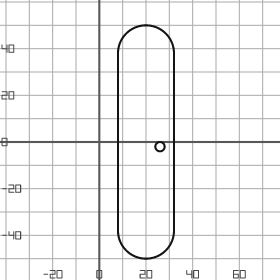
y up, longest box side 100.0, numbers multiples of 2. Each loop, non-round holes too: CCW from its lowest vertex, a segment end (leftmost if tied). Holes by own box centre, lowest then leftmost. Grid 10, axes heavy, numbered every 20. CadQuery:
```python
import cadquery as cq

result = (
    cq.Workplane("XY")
    .moveTo(8.0, -38.0)
    .threePointArc((20.0, -50.0), (32.0, -38.0))
    .lineTo(32.0, 38.0)
    .threePointArc((20.0, 50.0), (8.0, 38.0))
    .close()
    .moveTo(26.0, -2.0)
    .circle(2.0)
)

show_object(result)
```